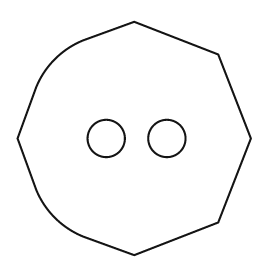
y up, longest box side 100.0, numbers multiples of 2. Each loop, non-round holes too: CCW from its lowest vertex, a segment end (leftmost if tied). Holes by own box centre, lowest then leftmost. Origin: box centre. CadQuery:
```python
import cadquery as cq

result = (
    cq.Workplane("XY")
    .moveTo(0.0, -50.0)
    .lineTo(36.0, -36.0)
    .lineTo(50.0, 0.0)
    .lineTo(36.0, 36.0)
    .lineTo(0.0, 50.0)
    .lineTo(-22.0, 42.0)
    .threePointArc((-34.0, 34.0), (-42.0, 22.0))
    .lineTo(-50.0, 0.0)
    .lineTo(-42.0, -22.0)
    .threePointArc((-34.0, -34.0), (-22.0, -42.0))
    .close()
    .moveTo(-12.0, 0.0)
    .circle(8.0)
    .moveTo(14.0, 0.0)
    .circle(8.0)
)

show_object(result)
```